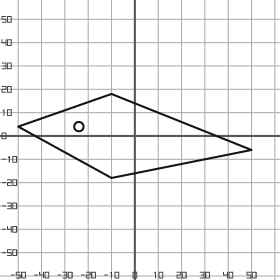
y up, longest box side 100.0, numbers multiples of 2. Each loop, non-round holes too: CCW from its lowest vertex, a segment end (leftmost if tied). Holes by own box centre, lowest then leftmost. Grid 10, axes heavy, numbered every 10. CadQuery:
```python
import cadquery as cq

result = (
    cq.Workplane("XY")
    .moveTo(-10.0, -18.0)
    .lineTo(50.0, -6.0)
    .lineTo(-10.0, 18.0)
    .lineTo(-50.0, 4.0)
    .close()
    .moveTo(-24.0, 4.0)
    .circle(2.0)
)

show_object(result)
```